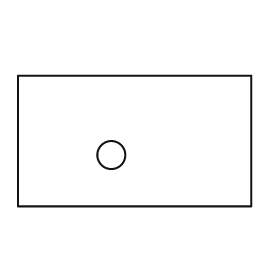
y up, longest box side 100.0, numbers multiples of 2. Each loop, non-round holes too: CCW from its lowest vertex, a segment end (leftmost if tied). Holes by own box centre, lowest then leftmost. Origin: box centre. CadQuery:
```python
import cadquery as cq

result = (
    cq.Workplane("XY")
    .moveTo(-50.0, -28.0)
    .lineTo(50.0, -28.0)
    .lineTo(50.0, 28.0)
    .lineTo(-50.0, 28.0)
    .close()
    .moveTo(-10.0, -6.0)
    .circle(6.0)
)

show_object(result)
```